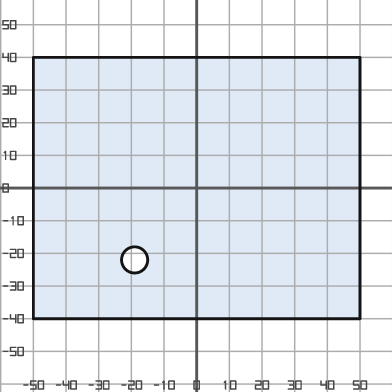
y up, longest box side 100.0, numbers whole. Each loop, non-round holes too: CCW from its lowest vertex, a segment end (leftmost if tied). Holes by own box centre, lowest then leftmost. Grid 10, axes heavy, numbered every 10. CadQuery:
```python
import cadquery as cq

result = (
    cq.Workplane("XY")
    .moveTo(-50.0, -40.0)
    .lineTo(50.0, -40.0)
    .lineTo(50.0, 40.0)
    .lineTo(-50.0, 40.0)
    .close()
    .moveTo(-19.0, -22.0)
    .circle(4.0)
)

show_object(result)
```